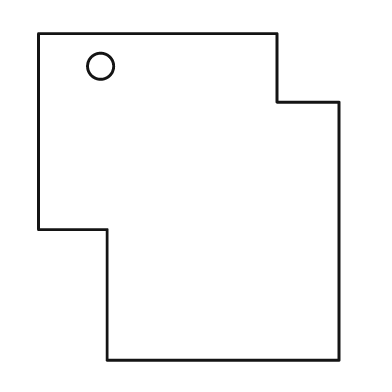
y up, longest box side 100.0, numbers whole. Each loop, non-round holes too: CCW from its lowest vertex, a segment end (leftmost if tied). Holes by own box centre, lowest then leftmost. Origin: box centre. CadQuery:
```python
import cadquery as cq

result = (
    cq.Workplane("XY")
    .moveTo(-25.0, -50.0)
    .lineTo(46.0, -50.0)
    .lineTo(46.0, 29.0)
    .lineTo(27.0, 29.0)
    .lineTo(27.0, 50.0)
    .lineTo(-46.0, 50.0)
    .lineTo(-46.0, -10.0)
    .lineTo(-25.0, -10.0)
    .close()
    .moveTo(-27.0, 40.0)
    .circle(4.0)
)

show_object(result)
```